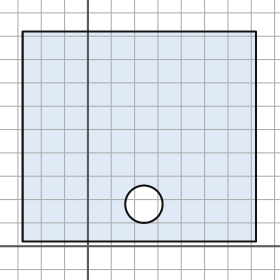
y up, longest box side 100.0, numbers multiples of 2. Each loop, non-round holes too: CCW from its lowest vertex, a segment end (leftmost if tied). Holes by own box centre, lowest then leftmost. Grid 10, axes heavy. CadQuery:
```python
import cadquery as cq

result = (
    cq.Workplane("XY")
    .moveTo(-28.0, 2.0)
    .lineTo(72.0, 2.0)
    .lineTo(72.0, 92.0)
    .lineTo(-28.0, 92.0)
    .close()
    .moveTo(24.0, 18.0)
    .circle(8.0)
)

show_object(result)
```